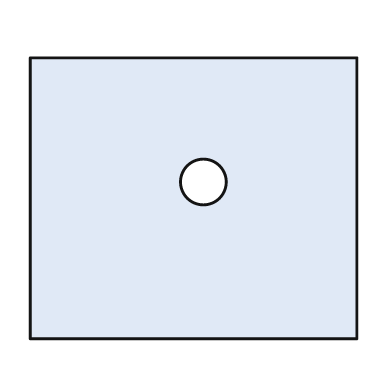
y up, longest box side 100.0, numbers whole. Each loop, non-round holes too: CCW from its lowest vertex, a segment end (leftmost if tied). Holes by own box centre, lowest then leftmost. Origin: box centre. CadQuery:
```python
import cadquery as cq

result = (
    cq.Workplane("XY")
    .moveTo(-50.0, -43.0)
    .lineTo(50.0, -43.0)
    .lineTo(50.0, 43.0)
    .lineTo(-50.0, 43.0)
    .close()
    .moveTo(3.0, 5.0)
    .circle(7.0)
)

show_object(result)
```